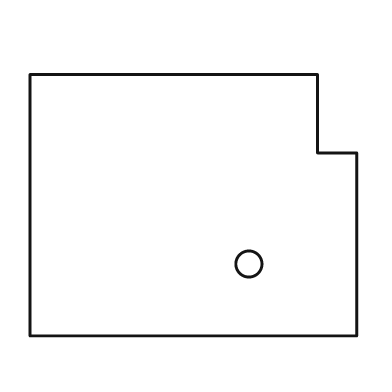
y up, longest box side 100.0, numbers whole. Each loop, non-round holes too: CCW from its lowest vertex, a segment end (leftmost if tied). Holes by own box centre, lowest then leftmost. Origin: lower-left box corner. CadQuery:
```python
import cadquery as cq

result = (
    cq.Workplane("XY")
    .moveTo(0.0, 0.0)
    .lineTo(100.0, 0.0)
    .lineTo(100.0, 56.0)
    .lineTo(88.0, 56.0)
    .lineTo(88.0, 80.0)
    .lineTo(0.0, 80.0)
    .close()
    .moveTo(67.0, 22.0)
    .circle(4.0)
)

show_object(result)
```